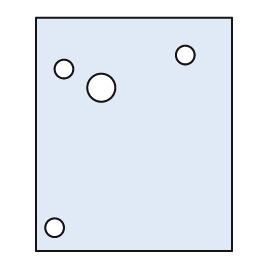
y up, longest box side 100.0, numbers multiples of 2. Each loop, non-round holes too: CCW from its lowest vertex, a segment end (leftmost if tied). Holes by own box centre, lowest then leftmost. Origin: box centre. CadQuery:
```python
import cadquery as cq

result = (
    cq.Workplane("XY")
    .moveTo(-42.0, -50.0)
    .lineTo(42.0, -50.0)
    .lineTo(42.0, 50.0)
    .lineTo(-42.0, 50.0)
    .close()
    .moveTo(-34.0, -40.0)
    .circle(4.0)
    .moveTo(-14.0, 20.0)
    .circle(6.0)
    .moveTo(-30.0, 28.0)
    .circle(4.0)
    .moveTo(22.0, 34.0)
    .circle(4.0)
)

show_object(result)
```